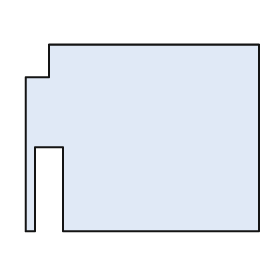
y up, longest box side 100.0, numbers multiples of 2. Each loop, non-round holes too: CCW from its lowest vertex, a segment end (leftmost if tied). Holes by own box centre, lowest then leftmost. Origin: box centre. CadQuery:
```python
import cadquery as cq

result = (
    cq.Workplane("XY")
    .moveTo(-50.0, -40.0)
    .lineTo(-46.0, -40.0)
    .lineTo(-46.0, -4.0)
    .lineTo(-34.0, -4.0)
    .lineTo(-34.0, -40.0)
    .lineTo(50.0, -40.0)
    .lineTo(50.0, 40.0)
    .lineTo(-40.0, 40.0)
    .lineTo(-40.0, 26.0)
    .lineTo(-50.0, 26.0)
    .close()
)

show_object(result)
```